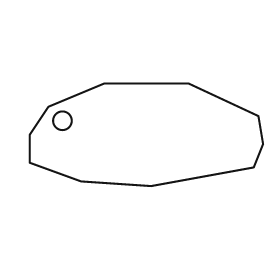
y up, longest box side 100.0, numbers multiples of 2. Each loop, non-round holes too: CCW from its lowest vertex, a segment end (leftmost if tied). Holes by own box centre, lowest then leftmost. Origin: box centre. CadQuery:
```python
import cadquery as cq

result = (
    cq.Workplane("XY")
    .moveTo(2.0, -22.0)
    .lineTo(46.0, -14.0)
    .lineTo(50.0, -4.0)
    .lineTo(48.0, 8.0)
    .lineTo(18.0, 22.0)
    .lineTo(-18.0, 22.0)
    .lineTo(-42.0, 12.0)
    .lineTo(-50.0, 0.0)
    .lineTo(-50.0, -12.0)
    .lineTo(-28.0, -20.0)
    .close()
    .moveTo(-36.0, 6.0)
    .circle(4.0)
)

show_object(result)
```